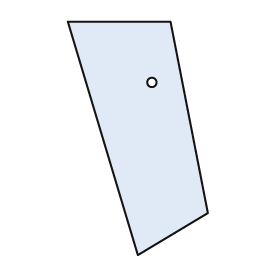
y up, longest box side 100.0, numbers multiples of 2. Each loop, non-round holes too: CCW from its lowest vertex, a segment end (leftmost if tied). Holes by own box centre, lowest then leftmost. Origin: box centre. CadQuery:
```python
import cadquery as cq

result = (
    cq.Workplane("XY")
    .moveTo(0.0, -50.0)
    .lineTo(30.0, -32.0)
    .lineTo(14.0, 50.0)
    .lineTo(-30.0, 50.0)
    .close()
    .moveTo(6.0, 24.0)
    .circle(2.0)
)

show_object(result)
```